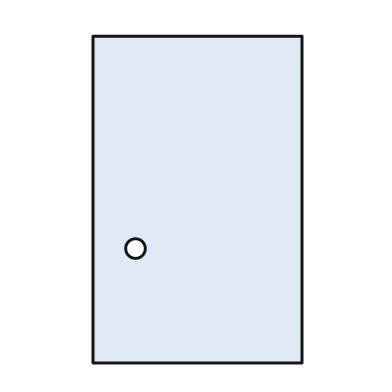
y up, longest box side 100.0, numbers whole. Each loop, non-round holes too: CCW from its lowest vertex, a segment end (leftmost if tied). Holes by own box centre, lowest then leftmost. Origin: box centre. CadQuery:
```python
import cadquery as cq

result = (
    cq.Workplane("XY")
    .moveTo(-32.0, -50.0)
    .lineTo(32.0, -50.0)
    .lineTo(32.0, 50.0)
    .lineTo(-32.0, 50.0)
    .close()
    .moveTo(-19.0, -15.0)
    .circle(3.0)
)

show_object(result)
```